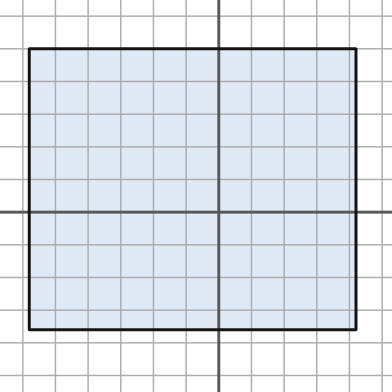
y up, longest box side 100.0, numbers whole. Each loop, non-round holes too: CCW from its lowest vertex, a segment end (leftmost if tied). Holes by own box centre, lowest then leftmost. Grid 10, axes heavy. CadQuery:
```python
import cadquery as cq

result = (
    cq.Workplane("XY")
    .moveTo(-58.0, -36.0)
    .lineTo(42.0, -36.0)
    .lineTo(42.0, 50.0)
    .lineTo(-58.0, 50.0)
    .close()
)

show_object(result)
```